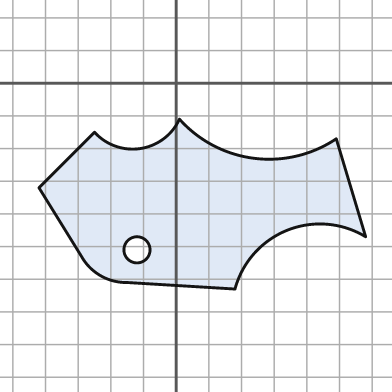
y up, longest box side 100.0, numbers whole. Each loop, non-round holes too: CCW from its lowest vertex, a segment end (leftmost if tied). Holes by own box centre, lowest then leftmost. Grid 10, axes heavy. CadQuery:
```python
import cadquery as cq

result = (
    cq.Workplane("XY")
    .moveTo(18.0, -63.0)
    .threePointArc((34.0, -45.0), (58.0, -47.0))
    .lineTo(49.0, -17.0)
    .threePointArc((24.0, -23.0), (1.0, -11.0))
    .threePointArc((-11.0, -20.0), (-25.0, -15.0))
    .lineTo(-42.0, -32.0)
    .lineTo(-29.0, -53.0)
    .threePointArc((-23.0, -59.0), (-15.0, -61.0))
    .close()
    .moveTo(-12.0, -51.0)
    .circle(4.0)
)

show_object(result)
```